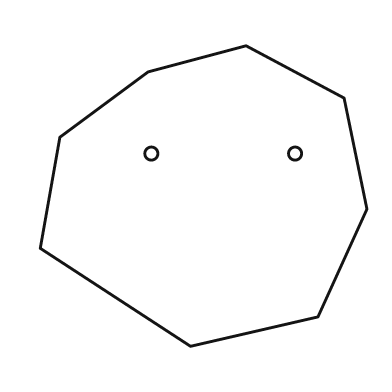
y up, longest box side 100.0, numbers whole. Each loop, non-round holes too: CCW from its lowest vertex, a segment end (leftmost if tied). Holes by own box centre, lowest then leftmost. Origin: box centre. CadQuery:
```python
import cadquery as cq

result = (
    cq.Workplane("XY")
    .moveTo(-4.0, -46.0)
    .lineTo(35.0, -37.0)
    .lineTo(50.0, -4.0)
    .lineTo(43.0, 30.0)
    .lineTo(13.0, 46.0)
    .lineTo(-17.0, 38.0)
    .lineTo(-44.0, 18.0)
    .lineTo(-50.0, -16.0)
    .close()
    .moveTo(-16.0, 13.0)
    .circle(2.0)
    .moveTo(28.0, 13.0)
    .circle(2.0)
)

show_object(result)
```